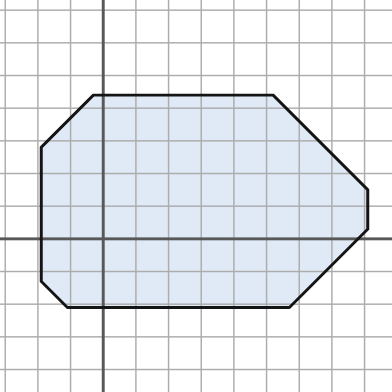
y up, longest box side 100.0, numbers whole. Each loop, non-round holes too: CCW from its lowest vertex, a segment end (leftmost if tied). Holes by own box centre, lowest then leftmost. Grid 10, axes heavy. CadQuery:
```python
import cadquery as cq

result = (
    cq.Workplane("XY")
    .moveTo(-11.0, -21.0)
    .lineTo(57.0, -21.0)
    .lineTo(81.0, 3.0)
    .lineTo(81.0, 15.0)
    .lineTo(52.0, 44.0)
    .lineTo(-3.0, 44.0)
    .lineTo(-19.0, 28.0)
    .lineTo(-19.0, -13.0)
    .close()
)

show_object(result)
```